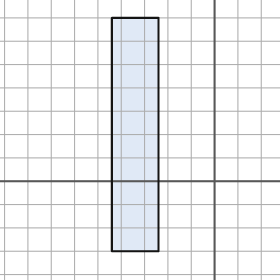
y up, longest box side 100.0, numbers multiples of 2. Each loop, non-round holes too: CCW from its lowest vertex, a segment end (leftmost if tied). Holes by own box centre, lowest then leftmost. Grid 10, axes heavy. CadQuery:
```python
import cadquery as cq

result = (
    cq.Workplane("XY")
    .moveTo(-44.0, -30.0)
    .lineTo(-24.0, -30.0)
    .lineTo(-24.0, 70.0)
    .lineTo(-44.0, 70.0)
    .close()
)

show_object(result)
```